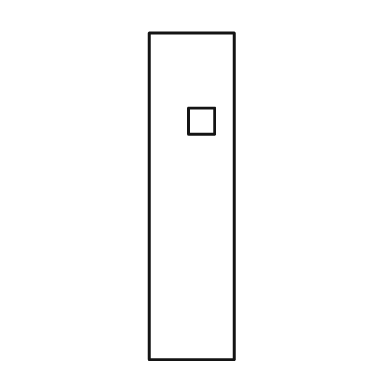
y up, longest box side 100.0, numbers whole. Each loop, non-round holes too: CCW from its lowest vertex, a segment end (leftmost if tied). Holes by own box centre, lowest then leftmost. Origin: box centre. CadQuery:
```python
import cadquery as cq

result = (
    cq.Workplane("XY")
    .moveTo(-13.0, -50.0)
    .lineTo(13.0, -50.0)
    .lineTo(13.0, 50.0)
    .lineTo(-13.0, 50.0)
    .close()
    .moveTo(-1.0, 19.0)
    .lineTo(7.0, 19.0)
    .lineTo(7.0, 27.0)
    .lineTo(-1.0, 27.0)
    .close()
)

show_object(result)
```